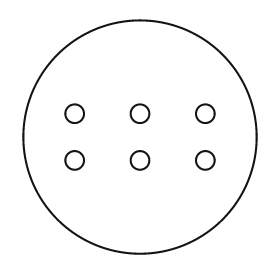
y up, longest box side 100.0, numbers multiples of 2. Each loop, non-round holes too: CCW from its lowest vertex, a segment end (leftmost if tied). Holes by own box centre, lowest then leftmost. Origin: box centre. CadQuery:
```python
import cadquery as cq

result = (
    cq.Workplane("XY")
    .moveTo(0.0, 0.0)
    .circle(50.0)
    .moveTo(-28.0, -10.0)
    .circle(4.0)
    .moveTo(0.0, -10.0)
    .circle(4.0)
    .moveTo(28.0, -10.0)
    .circle(4.0)
    .moveTo(-28.0, 10.0)
    .circle(4.0)
    .moveTo(0.0, 10.0)
    .circle(4.0)
    .moveTo(28.0, 10.0)
    .circle(4.0)
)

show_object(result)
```